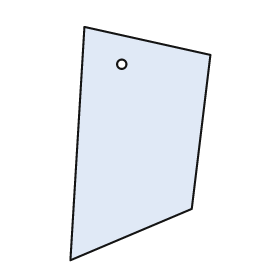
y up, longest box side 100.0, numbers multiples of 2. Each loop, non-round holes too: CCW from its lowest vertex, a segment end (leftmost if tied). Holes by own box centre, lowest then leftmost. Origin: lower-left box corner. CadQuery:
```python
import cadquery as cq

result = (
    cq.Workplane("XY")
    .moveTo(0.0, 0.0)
    .lineTo(52.0, 22.0)
    .lineTo(60.0, 88.0)
    .lineTo(6.0, 100.0)
    .close()
    .moveTo(22.0, 84.0)
    .circle(2.0)
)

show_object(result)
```